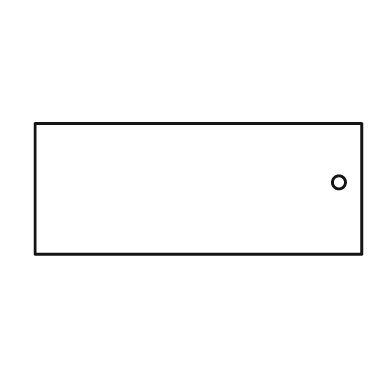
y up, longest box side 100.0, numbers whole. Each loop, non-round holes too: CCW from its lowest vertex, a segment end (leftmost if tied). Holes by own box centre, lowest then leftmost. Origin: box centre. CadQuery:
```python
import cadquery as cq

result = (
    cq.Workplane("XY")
    .moveTo(-50.0, -20.0)
    .lineTo(50.0, -20.0)
    .lineTo(50.0, 20.0)
    .lineTo(-50.0, 20.0)
    .close()
    .moveTo(43.0, 2.0)
    .circle(2.0)
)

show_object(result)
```